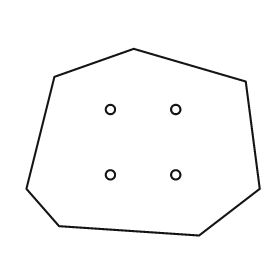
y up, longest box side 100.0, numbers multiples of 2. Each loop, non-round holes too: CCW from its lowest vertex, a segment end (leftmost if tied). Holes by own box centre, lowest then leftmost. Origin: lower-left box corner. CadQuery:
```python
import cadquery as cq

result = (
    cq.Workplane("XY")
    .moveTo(74.0, 0.0)
    .lineTo(100.0, 20.0)
    .lineTo(94.0, 66.0)
    .lineTo(46.0, 80.0)
    .lineTo(12.0, 68.0)
    .lineTo(0.0, 20.0)
    .lineTo(14.0, 4.0)
    .close()
    .moveTo(36.0, 26.0)
    .circle(2.0)
    .moveTo(64.0, 26.0)
    .circle(2.0)
    .moveTo(36.0, 54.0)
    .circle(2.0)
    .moveTo(64.0, 54.0)
    .circle(2.0)
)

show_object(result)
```